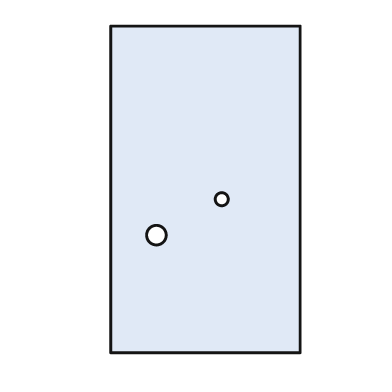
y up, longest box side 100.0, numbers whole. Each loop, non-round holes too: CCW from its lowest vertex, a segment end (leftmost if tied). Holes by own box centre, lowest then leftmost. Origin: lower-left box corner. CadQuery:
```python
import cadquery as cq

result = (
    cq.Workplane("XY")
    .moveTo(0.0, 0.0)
    .lineTo(58.0, 0.0)
    .lineTo(58.0, 100.0)
    .lineTo(0.0, 100.0)
    .close()
    .moveTo(14.0, 36.0)
    .circle(3.0)
    .moveTo(34.0, 47.0)
    .circle(2.0)
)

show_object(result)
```